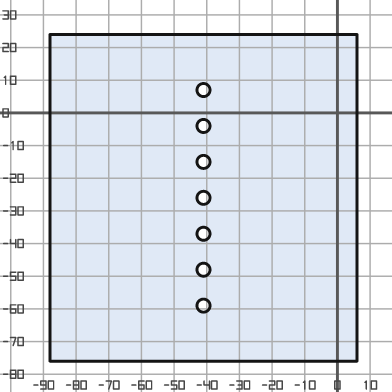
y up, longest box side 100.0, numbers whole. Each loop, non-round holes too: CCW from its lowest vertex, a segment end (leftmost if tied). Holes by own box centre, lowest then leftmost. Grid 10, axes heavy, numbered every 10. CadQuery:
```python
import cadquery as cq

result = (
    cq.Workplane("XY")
    .moveTo(-88.0, -76.0)
    .lineTo(6.0, -76.0)
    .lineTo(6.0, 24.0)
    .lineTo(-88.0, 24.0)
    .close()
    .moveTo(-41.0, -59.0)
    .circle(2.0)
    .moveTo(-41.0, -48.0)
    .circle(2.0)
    .moveTo(-41.0, -37.0)
    .circle(2.0)
    .moveTo(-41.0, -26.0)
    .circle(2.0)
    .moveTo(-41.0, -15.0)
    .circle(2.0)
    .moveTo(-41.0, -4.0)
    .circle(2.0)
    .moveTo(-41.0, 7.0)
    .circle(2.0)
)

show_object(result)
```